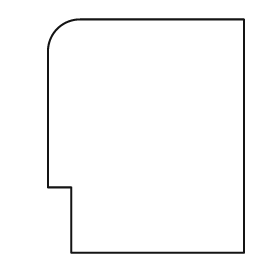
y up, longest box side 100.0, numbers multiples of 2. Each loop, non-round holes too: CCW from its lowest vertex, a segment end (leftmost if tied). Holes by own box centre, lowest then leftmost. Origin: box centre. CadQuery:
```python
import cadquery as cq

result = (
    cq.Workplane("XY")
    .moveTo(-32.0, -50.0)
    .lineTo(42.0, -50.0)
    .lineTo(42.0, 50.0)
    .lineTo(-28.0, 50.0)
    .threePointArc((-38.0, 46.0), (-42.0, 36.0))
    .lineTo(-42.0, -22.0)
    .lineTo(-32.0, -22.0)
    .close()
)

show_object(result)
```